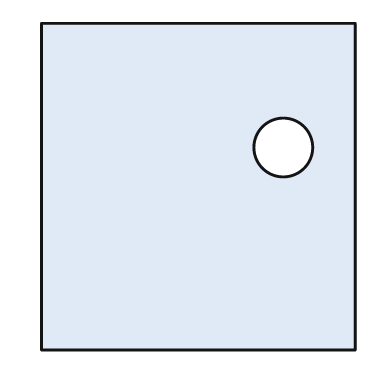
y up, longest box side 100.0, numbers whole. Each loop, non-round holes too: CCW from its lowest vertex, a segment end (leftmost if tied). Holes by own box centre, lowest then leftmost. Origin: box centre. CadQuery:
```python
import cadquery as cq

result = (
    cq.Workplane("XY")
    .moveTo(-48.0, -50.0)
    .lineTo(48.0, -50.0)
    .lineTo(48.0, 50.0)
    .lineTo(-48.0, 50.0)
    .close()
    .moveTo(26.0, 12.0)
    .circle(9.0)
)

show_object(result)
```